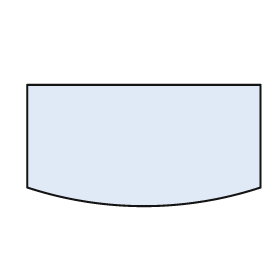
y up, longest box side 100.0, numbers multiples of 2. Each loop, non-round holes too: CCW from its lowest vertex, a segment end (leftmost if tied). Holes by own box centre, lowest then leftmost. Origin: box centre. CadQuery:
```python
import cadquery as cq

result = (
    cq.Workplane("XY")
    .moveTo(-50.0, -18.0)
    .threePointArc((0.0, -26.0), (50.0, -18.0))
    .lineTo(50.0, 26.0)
    .lineTo(-50.0, 26.0)
    .close()
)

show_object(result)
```